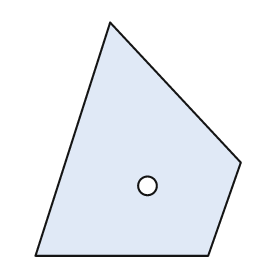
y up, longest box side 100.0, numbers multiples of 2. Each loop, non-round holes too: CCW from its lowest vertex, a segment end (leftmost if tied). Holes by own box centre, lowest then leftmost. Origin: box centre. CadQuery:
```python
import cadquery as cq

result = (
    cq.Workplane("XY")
    .moveTo(-44.0, -50.0)
    .lineTo(30.0, -50.0)
    .lineTo(44.0, -10.0)
    .lineTo(-12.0, 50.0)
    .close()
    .moveTo(4.0, -20.0)
    .circle(4.0)
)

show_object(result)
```